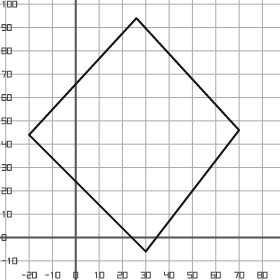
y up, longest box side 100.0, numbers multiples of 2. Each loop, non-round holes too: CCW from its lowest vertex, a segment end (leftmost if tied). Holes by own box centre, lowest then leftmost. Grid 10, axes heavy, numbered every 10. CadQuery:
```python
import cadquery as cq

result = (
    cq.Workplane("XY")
    .moveTo(30.0, -6.0)
    .lineTo(70.0, 46.0)
    .lineTo(26.0, 94.0)
    .lineTo(-20.0, 44.0)
    .close()
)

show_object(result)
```